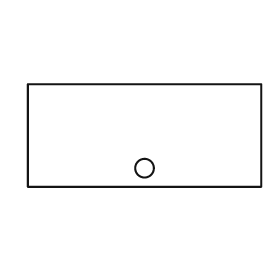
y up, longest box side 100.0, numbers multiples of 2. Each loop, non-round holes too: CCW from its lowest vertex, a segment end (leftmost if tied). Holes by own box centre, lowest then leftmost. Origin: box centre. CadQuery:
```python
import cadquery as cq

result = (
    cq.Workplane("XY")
    .moveTo(-50.0, -22.0)
    .lineTo(50.0, -22.0)
    .lineTo(50.0, 22.0)
    .lineTo(-50.0, 22.0)
    .close()
    .moveTo(0.0, -14.0)
    .circle(4.0)
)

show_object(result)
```